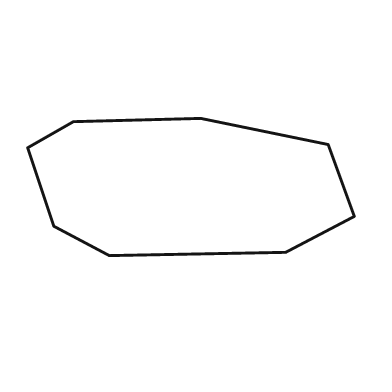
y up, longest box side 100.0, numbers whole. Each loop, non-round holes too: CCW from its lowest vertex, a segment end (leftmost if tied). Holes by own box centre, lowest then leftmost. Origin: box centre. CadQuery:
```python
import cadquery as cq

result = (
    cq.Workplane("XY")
    .moveTo(-25.0, -21.0)
    .lineTo(29.0, -20.0)
    .lineTo(50.0, -9.0)
    .lineTo(42.0, 13.0)
    .lineTo(3.0, 21.0)
    .lineTo(-36.0, 20.0)
    .lineTo(-50.0, 12.0)
    .lineTo(-42.0, -12.0)
    .close()
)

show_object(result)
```